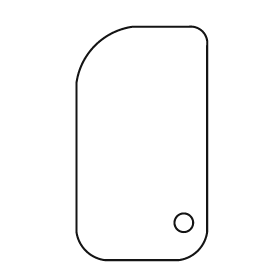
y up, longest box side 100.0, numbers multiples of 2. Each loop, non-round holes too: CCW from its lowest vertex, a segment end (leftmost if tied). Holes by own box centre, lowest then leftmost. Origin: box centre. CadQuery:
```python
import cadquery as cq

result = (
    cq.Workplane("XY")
    .moveTo(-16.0, -50.0)
    .lineTo(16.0, -50.0)
    .threePointArc((24.0, -46.0), (28.0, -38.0))
    .lineTo(28.0, 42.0)
    .threePointArc((26.0, 48.0), (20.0, 50.0))
    .lineTo(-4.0, 50.0)
    .threePointArc((-20.0, 42.0), (-28.0, 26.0))
    .lineTo(-28.0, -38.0)
    .threePointArc((-24.0, -46.0), (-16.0, -50.0))
    .close()
    .moveTo(18.0, -34.0)
    .circle(4.0)
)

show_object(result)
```